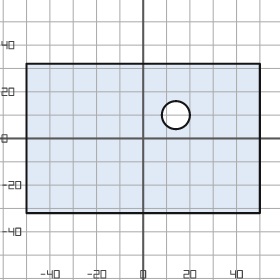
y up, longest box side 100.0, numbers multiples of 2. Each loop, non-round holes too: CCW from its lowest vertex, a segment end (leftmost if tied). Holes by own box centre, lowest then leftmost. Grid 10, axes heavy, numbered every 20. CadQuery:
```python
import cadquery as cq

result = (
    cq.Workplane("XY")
    .moveTo(-50.0, -32.0)
    .lineTo(50.0, -32.0)
    .lineTo(50.0, 32.0)
    .lineTo(-50.0, 32.0)
    .close()
    .moveTo(14.0, 10.0)
    .circle(6.0)
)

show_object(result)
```